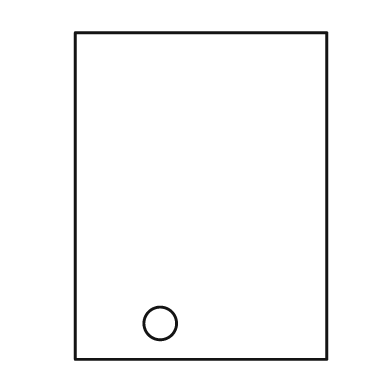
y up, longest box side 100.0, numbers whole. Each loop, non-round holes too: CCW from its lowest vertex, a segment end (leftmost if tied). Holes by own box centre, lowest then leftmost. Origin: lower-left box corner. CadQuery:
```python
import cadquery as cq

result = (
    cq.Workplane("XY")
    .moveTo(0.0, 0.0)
    .lineTo(77.0, 0.0)
    .lineTo(77.0, 100.0)
    .lineTo(0.0, 100.0)
    .close()
    .moveTo(26.0, 11.0)
    .circle(5.0)
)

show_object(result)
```